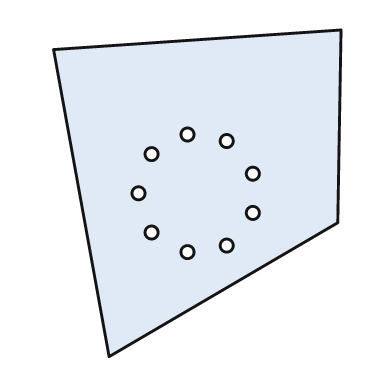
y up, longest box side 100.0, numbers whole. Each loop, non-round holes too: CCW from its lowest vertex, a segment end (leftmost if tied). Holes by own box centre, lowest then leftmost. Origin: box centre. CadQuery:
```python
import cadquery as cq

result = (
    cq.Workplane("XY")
    .moveTo(-27.0, -50.0)
    .lineTo(43.0, -9.0)
    .lineTo(44.0, 50.0)
    .lineTo(-44.0, 44.0)
    .close()
    .moveTo(-3.0, -18.0)
    .circle(2.0)
    .moveTo(9.0, -16.0)
    .circle(2.0)
    .moveTo(-14.0, -12.0)
    .circle(2.0)
    .moveTo(17.0, -6.0)
    .circle(2.0)
    .moveTo(-18.0, 0.0)
    .circle(2.0)
    .moveTo(17.0, 6.0)
    .circle(2.0)
    .moveTo(-14.0, 12.0)
    .circle(2.0)
    .moveTo(9.0, 16.0)
    .circle(2.0)
    .moveTo(-3.0, 18.0)
    .circle(2.0)
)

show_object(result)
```